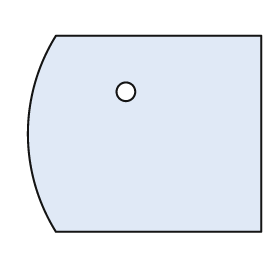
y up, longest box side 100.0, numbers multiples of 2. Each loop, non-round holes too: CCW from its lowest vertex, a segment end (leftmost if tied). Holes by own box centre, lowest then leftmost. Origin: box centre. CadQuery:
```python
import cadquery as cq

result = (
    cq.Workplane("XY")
    .moveTo(-38.0, -42.0)
    .lineTo(50.0, -42.0)
    .lineTo(50.0, 42.0)
    .lineTo(-38.0, 42.0)
    .threePointArc((-50.0, 0.0), (-38.0, -42.0))
    .close()
    .moveTo(-8.0, 18.0)
    .circle(4.0)
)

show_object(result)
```